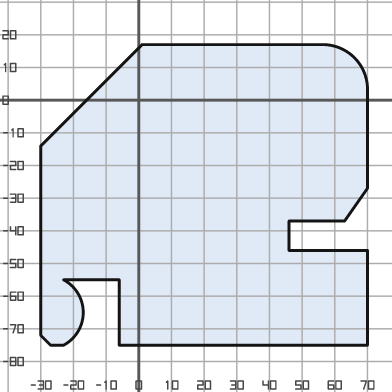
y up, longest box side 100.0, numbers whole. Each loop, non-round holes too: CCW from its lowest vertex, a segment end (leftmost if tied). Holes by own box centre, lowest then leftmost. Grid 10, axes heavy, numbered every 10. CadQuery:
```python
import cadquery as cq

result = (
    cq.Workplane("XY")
    .moveTo(-27.0, -75.0)
    .lineTo(-23.0, -75.0)
    .threePointArc((-17.0, -65.0), (-23.0, -55.0))
    .lineTo(-6.0, -55.0)
    .lineTo(-6.0, -75.0)
    .lineTo(70.0, -75.0)
    .lineTo(70.0, -46.0)
    .lineTo(46.0, -46.0)
    .lineTo(46.0, -37.0)
    .lineTo(63.0, -37.0)
    .lineTo(70.0, -27.0)
    .lineTo(70.0, 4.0)
    .threePointArc((66.0, 13.0), (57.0, 17.0))
    .lineTo(1.0, 17.0)
    .lineTo(-30.0, -14.0)
    .lineTo(-30.0, -72.0)
    .close()
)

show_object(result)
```